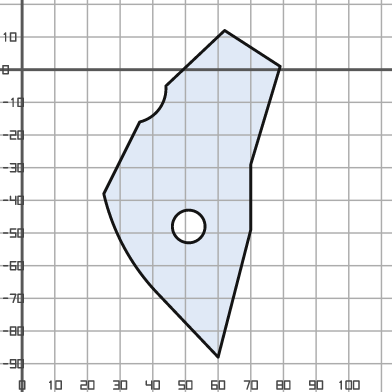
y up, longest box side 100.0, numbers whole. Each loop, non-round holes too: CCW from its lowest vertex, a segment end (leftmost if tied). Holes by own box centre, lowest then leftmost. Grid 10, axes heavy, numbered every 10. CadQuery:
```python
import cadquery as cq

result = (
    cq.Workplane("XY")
    .moveTo(60.0, -88.0)
    .lineTo(70.0, -49.0)
    .lineTo(70.0, -29.0)
    .lineTo(79.0, 1.0)
    .lineTo(62.0, 12.0)
    .lineTo(44.0, -5.0)
    .threePointArc((42.0, -12.0), (36.0, -16.0))
    .lineTo(25.0, -38.0)
    .threePointArc((31.0, -54.0), (41.0, -68.0))
    .close()
    .moveTo(51.0, -48.0)
    .circle(5.0)
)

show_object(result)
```